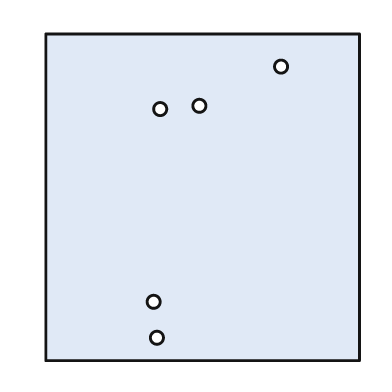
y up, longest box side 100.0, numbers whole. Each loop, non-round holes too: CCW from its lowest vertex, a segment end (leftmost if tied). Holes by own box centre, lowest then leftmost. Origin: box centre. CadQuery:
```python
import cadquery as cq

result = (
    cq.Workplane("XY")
    .moveTo(-48.0, -50.0)
    .lineTo(48.0, -50.0)
    .lineTo(48.0, 50.0)
    .lineTo(-48.0, 50.0)
    .close()
    .moveTo(-14.0, -43.0)
    .circle(2.0)
    .moveTo(-15.0, -32.0)
    .circle(2.0)
    .moveTo(-13.0, 27.0)
    .circle(2.0)
    .moveTo(-1.0, 28.0)
    .circle(2.0)
    .moveTo(24.0, 40.0)
    .circle(2.0)
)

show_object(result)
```